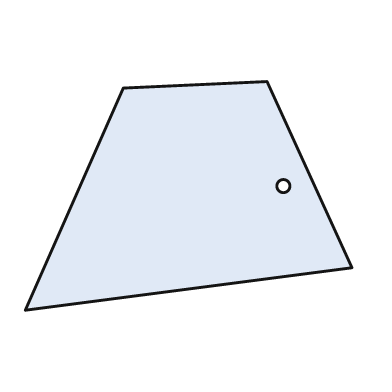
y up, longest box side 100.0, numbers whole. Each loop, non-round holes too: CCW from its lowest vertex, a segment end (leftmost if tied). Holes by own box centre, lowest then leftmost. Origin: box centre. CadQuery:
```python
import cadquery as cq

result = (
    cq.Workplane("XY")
    .moveTo(-50.0, -35.0)
    .lineTo(50.0, -22.0)
    .lineTo(24.0, 35.0)
    .lineTo(-20.0, 33.0)
    .close()
    .moveTo(29.0, 3.0)
    .circle(2.0)
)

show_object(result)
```